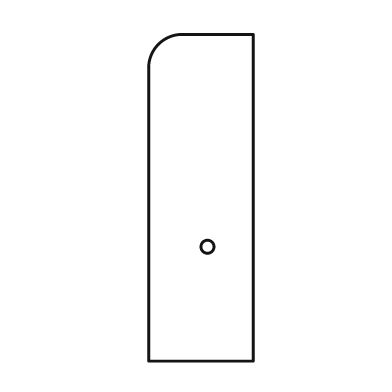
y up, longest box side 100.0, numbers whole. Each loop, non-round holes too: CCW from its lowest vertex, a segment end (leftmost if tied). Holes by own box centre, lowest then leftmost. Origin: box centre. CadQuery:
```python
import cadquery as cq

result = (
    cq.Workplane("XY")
    .moveTo(-16.0, -50.0)
    .lineTo(16.0, -50.0)
    .lineTo(16.0, 50.0)
    .lineTo(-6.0, 50.0)
    .threePointArc((-13.0, 47.0), (-16.0, 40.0))
    .close()
    .moveTo(2.0, -15.0)
    .circle(2.0)
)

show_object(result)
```